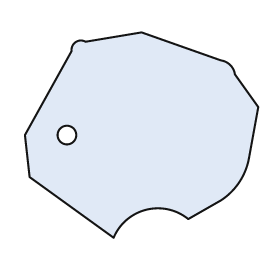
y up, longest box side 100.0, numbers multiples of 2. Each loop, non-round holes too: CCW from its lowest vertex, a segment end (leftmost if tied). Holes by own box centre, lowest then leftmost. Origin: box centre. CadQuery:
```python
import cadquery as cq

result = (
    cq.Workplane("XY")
    .moveTo(-12.0, -44.0)
    .threePointArc((2.0, -32.0), (20.0, -36.0))
    .lineTo(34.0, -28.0)
    .threePointArc((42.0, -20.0), (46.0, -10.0))
    .lineTo(50.0, 12.0)
    .lineTo(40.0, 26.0)
    .threePointArc((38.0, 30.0), (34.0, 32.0))
    .lineTo(0.0, 44.0)
    .lineTo(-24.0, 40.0)
    .threePointArc((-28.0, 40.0), (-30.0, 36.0))
    .lineTo(-50.0, 0.0)
    .lineTo(-48.0, -18.0)
    .close()
    .moveTo(-32.0, 0.0)
    .circle(4.0)
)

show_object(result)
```